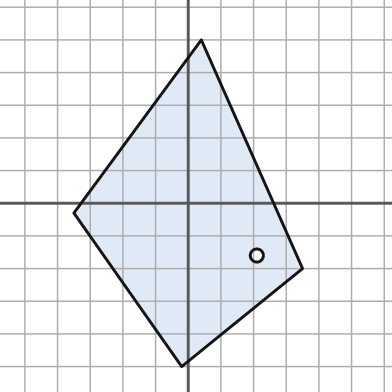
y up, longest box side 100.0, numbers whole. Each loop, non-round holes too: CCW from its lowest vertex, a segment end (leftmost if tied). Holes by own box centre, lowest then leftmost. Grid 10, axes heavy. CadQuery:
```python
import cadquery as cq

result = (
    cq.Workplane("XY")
    .moveTo(-2.0, -50.0)
    .lineTo(35.0, -20.0)
    .lineTo(4.0, 50.0)
    .lineTo(-35.0, -3.0)
    .close()
    .moveTo(21.0, -16.0)
    .circle(2.0)
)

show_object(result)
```